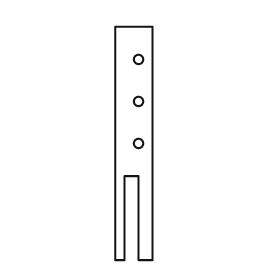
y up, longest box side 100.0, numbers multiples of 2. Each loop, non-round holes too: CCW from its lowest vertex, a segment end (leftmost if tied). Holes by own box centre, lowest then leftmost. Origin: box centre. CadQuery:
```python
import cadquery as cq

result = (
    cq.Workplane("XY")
    .moveTo(-8.0, -50.0)
    .lineTo(-4.0, -50.0)
    .lineTo(-4.0, -14.0)
    .lineTo(2.0, -14.0)
    .lineTo(2.0, -50.0)
    .lineTo(8.0, -50.0)
    .lineTo(8.0, 50.0)
    .lineTo(-8.0, 50.0)
    .close()
    .moveTo(2.0, 0.0)
    .circle(2.0)
    .moveTo(2.0, 18.0)
    .circle(2.0)
    .moveTo(2.0, 36.0)
    .circle(2.0)
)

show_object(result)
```